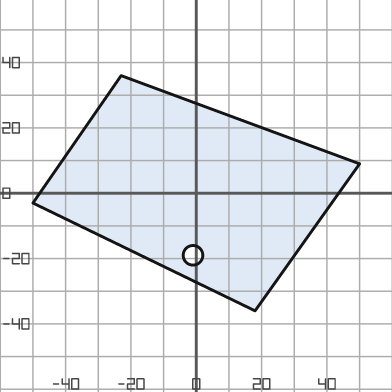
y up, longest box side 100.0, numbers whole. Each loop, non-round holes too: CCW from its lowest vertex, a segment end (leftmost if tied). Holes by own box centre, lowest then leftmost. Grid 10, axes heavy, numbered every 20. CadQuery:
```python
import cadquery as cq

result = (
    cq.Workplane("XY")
    .moveTo(18.0, -36.0)
    .lineTo(50.0, 9.0)
    .lineTo(-23.0, 36.0)
    .lineTo(-50.0, -3.0)
    .close()
    .moveTo(-1.0, -19.0)
    .circle(3.0)
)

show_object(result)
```